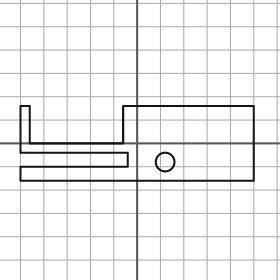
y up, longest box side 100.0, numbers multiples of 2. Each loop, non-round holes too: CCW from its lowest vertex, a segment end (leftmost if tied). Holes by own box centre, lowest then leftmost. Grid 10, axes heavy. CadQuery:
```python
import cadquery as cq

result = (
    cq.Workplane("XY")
    .moveTo(-50.0, -16.0)
    .lineTo(50.0, -16.0)
    .lineTo(50.0, 16.0)
    .lineTo(-6.0, 16.0)
    .lineTo(-6.0, 0.0)
    .lineTo(-46.0, 0.0)
    .lineTo(-46.0, 16.0)
    .lineTo(-50.0, 16.0)
    .lineTo(-50.0, -4.0)
    .lineTo(-4.0, -4.0)
    .lineTo(-4.0, -10.0)
    .lineTo(-50.0, -10.0)
    .close()
    .moveTo(12.0, -8.0)
    .circle(4.0)
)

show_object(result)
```